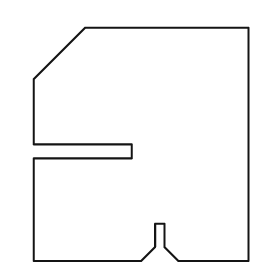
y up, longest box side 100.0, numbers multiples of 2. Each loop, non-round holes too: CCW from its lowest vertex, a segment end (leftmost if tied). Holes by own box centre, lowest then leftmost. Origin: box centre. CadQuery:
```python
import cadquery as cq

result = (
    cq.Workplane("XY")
    .moveTo(-46.0, -50.0)
    .lineTo(0.0, -50.0)
    .lineTo(6.0, -44.0)
    .lineTo(6.0, -34.0)
    .lineTo(10.0, -34.0)
    .lineTo(10.0, -44.0)
    .lineTo(16.0, -50.0)
    .lineTo(46.0, -50.0)
    .lineTo(46.0, 50.0)
    .lineTo(-24.0, 50.0)
    .lineTo(-46.0, 28.0)
    .lineTo(-46.0, 0.0)
    .lineTo(-4.0, 0.0)
    .lineTo(-4.0, -6.0)
    .lineTo(-46.0, -6.0)
    .close()
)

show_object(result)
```